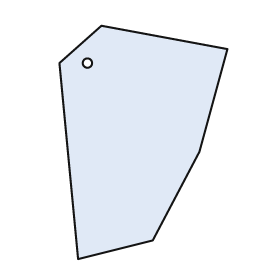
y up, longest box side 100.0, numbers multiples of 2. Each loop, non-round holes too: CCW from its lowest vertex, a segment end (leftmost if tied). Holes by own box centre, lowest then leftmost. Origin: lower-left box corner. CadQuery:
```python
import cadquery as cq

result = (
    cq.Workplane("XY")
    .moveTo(8.0, 0.0)
    .lineTo(40.0, 8.0)
    .lineTo(60.0, 46.0)
    .lineTo(72.0, 90.0)
    .lineTo(18.0, 100.0)
    .lineTo(0.0, 84.0)
    .close()
    .moveTo(12.0, 84.0)
    .circle(2.0)
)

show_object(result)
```